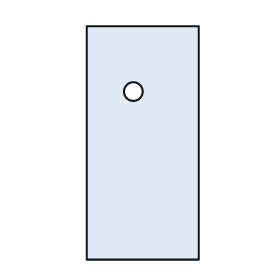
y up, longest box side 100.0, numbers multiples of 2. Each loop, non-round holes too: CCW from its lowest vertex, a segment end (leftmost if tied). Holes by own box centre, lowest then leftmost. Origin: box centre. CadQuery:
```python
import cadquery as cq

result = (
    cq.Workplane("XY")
    .moveTo(-24.0, -50.0)
    .lineTo(24.0, -50.0)
    .lineTo(24.0, 50.0)
    .lineTo(-24.0, 50.0)
    .close()
    .moveTo(-4.0, 22.0)
    .circle(4.0)
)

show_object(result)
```